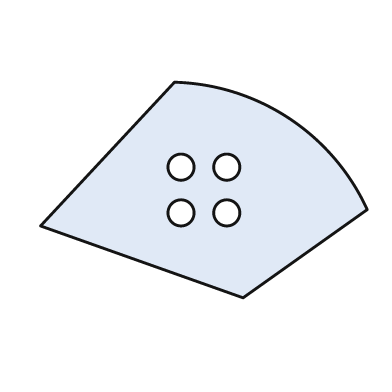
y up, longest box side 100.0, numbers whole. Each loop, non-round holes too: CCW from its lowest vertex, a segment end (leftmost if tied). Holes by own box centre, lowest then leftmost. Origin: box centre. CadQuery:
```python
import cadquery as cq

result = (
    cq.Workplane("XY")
    .moveTo(12.0, -33.0)
    .lineTo(50.0, -6.0)
    .threePointArc((26.0, 22.0), (-9.0, 33.0))
    .lineTo(-50.0, -11.0)
    .close()
    .moveTo(-7.0, -7.0)
    .circle(4.0)
    .moveTo(7.0, -7.0)
    .circle(4.0)
    .moveTo(-7.0, 7.0)
    .circle(4.0)
    .moveTo(7.0, 7.0)
    .circle(4.0)
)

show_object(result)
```